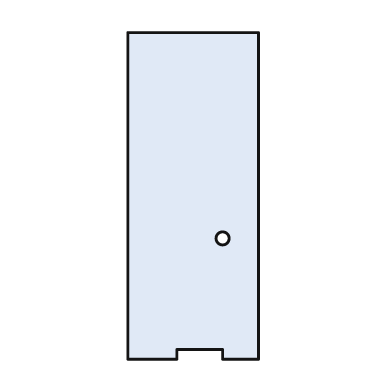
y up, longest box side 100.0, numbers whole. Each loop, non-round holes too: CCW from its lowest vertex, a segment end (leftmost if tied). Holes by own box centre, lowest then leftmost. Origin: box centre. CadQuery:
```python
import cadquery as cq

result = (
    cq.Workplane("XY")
    .moveTo(-20.0, -50.0)
    .lineTo(-5.0, -50.0)
    .lineTo(-5.0, -47.0)
    .lineTo(9.0, -47.0)
    .lineTo(9.0, -50.0)
    .lineTo(20.0, -50.0)
    .lineTo(20.0, 50.0)
    .lineTo(-20.0, 50.0)
    .close()
    .moveTo(9.0, -13.0)
    .circle(2.0)
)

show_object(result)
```